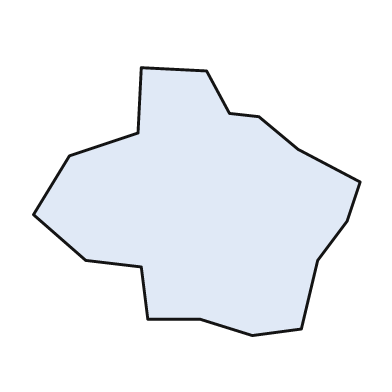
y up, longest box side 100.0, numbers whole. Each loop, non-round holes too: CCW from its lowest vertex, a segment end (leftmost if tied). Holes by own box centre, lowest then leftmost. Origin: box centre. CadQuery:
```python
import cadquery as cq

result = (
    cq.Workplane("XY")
    .moveTo(17.0, -41.0)
    .lineTo(32.0, -39.0)
    .lineTo(37.0, -18.0)
    .lineTo(46.0, -6.0)
    .lineTo(50.0, 6.0)
    .lineTo(31.0, 16.0)
    .lineTo(19.0, 26.0)
    .lineTo(10.0, 27.0)
    .lineTo(3.0, 40.0)
    .lineTo(-17.0, 41.0)
    .lineTo(-18.0, 21.0)
    .lineTo(-39.0, 14.0)
    .lineTo(-50.0, -4.0)
    .lineTo(-34.0, -18.0)
    .lineTo(-17.0, -20.0)
    .lineTo(-15.0, -36.0)
    .lineTo(1.0, -36.0)
    .close()
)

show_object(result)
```